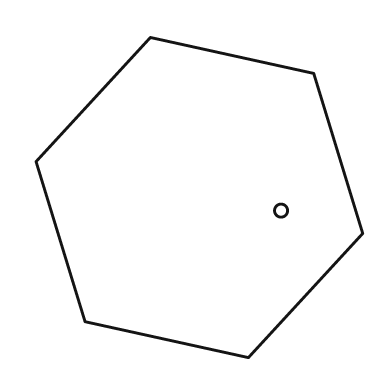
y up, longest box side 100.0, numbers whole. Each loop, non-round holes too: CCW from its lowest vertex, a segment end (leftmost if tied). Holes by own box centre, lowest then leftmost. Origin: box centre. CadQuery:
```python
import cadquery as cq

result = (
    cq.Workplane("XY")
    .moveTo(15.0, -49.0)
    .lineTo(50.0, -11.0)
    .lineTo(35.0, 38.0)
    .lineTo(-15.0, 49.0)
    .lineTo(-50.0, 11.0)
    .lineTo(-35.0, -38.0)
    .close()
    .moveTo(25.0, -4.0)
    .circle(2.0)
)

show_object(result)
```